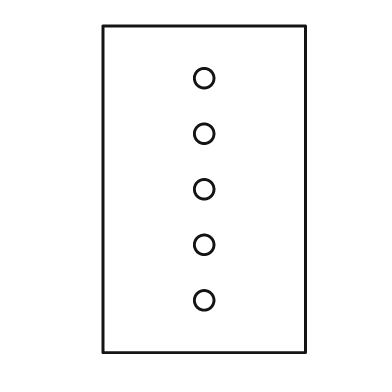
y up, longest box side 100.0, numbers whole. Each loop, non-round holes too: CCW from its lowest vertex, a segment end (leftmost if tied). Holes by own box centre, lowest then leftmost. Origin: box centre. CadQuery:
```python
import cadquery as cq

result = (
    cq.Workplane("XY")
    .moveTo(-31.0, -50.0)
    .lineTo(31.0, -50.0)
    .lineTo(31.0, 50.0)
    .lineTo(-31.0, 50.0)
    .close()
    .moveTo(0.0, -34.0)
    .circle(3.0)
    .moveTo(0.0, -17.0)
    .circle(3.0)
    .moveTo(0.0, 0.0)
    .circle(3.0)
    .moveTo(0.0, 17.0)
    .circle(3.0)
    .moveTo(0.0, 34.0)
    .circle(3.0)
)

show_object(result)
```